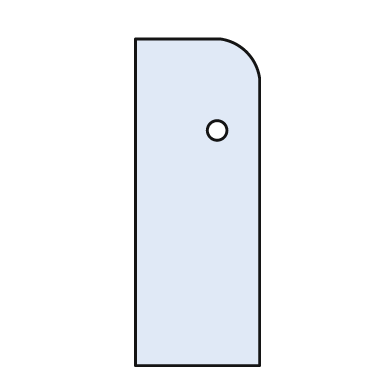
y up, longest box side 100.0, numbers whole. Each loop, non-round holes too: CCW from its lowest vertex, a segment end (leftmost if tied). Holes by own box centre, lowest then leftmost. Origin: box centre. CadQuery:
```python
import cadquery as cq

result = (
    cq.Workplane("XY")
    .moveTo(-19.0, -50.0)
    .lineTo(19.0, -50.0)
    .lineTo(19.0, 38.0)
    .threePointArc((15.0, 46.0), (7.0, 50.0))
    .lineTo(-19.0, 50.0)
    .close()
    .moveTo(6.0, 22.0)
    .circle(3.0)
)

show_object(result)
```